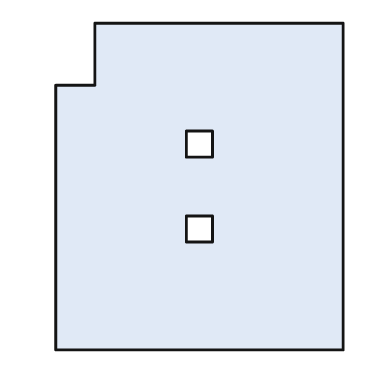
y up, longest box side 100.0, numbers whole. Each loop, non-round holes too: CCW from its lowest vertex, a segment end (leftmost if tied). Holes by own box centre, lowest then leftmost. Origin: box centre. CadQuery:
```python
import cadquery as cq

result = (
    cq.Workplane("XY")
    .moveTo(-44.0, -50.0)
    .lineTo(44.0, -50.0)
    .lineTo(44.0, 50.0)
    .lineTo(-32.0, 50.0)
    .lineTo(-32.0, 31.0)
    .lineTo(-44.0, 31.0)
    .close()
    .moveTo(-4.0, -17.0)
    .lineTo(4.0, -17.0)
    .lineTo(4.0, -9.0)
    .lineTo(-4.0, -9.0)
    .close()
    .moveTo(-4.0, 9.0)
    .lineTo(4.0, 9.0)
    .lineTo(4.0, 17.0)
    .lineTo(-4.0, 17.0)
    .close()
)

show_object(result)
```